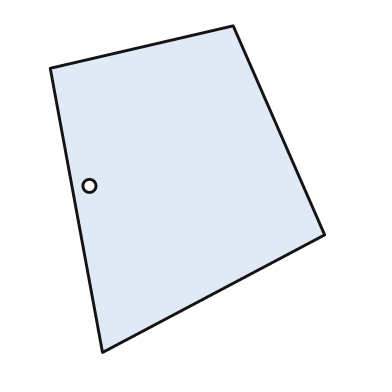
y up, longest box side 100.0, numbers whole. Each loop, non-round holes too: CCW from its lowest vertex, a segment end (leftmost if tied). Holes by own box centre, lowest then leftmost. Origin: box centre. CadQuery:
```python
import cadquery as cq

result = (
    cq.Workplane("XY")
    .moveTo(-26.0, -50.0)
    .lineTo(42.0, -14.0)
    .lineTo(14.0, 50.0)
    .lineTo(-42.0, 37.0)
    .close()
    .moveTo(-30.0, 1.0)
    .circle(2.0)
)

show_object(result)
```